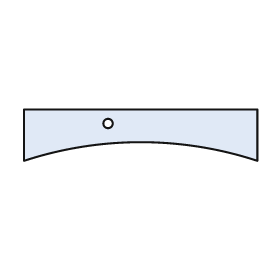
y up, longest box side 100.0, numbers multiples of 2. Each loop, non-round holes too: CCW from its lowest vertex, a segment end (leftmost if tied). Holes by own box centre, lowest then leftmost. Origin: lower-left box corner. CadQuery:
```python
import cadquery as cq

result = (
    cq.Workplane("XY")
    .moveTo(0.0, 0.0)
    .threePointArc((50.0, 8.0), (100.0, 0.0))
    .lineTo(100.0, 22.0)
    .lineTo(0.0, 22.0)
    .close()
    .moveTo(36.0, 16.0)
    .circle(2.0)
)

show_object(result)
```